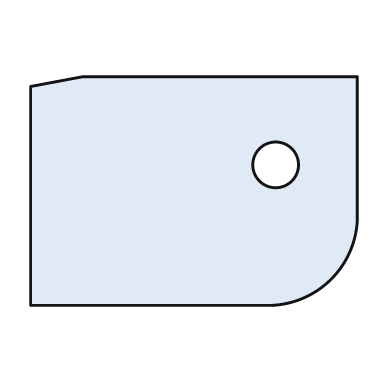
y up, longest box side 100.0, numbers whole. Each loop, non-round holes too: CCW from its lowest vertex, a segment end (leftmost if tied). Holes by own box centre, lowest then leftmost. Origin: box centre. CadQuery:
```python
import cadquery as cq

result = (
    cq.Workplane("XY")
    .moveTo(-50.0, -35.0)
    .lineTo(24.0, -35.0)
    .threePointArc((42.0, -27.0), (50.0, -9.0))
    .lineTo(50.0, 35.0)
    .lineTo(-34.0, 35.0)
    .lineTo(-50.0, 32.0)
    .close()
    .moveTo(25.0, 8.0)
    .circle(7.0)
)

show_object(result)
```